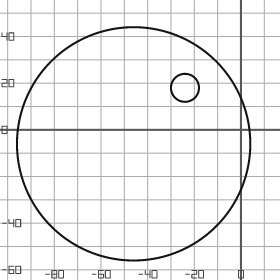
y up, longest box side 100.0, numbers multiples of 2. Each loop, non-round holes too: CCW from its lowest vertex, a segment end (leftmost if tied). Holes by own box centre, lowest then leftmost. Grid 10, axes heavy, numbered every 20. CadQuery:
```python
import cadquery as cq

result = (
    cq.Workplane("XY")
    .moveTo(-46.0, -6.0)
    .circle(50.0)
    .moveTo(-24.0, 18.0)
    .circle(6.0)
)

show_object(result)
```